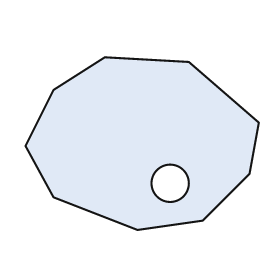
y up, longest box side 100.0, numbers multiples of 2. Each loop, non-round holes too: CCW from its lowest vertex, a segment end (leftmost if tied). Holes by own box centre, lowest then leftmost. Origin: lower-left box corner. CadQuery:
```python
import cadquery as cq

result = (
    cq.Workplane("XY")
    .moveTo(48.0, 0.0)
    .lineTo(76.0, 4.0)
    .lineTo(96.0, 24.0)
    .lineTo(100.0, 46.0)
    .lineTo(70.0, 72.0)
    .lineTo(34.0, 74.0)
    .lineTo(12.0, 60.0)
    .lineTo(0.0, 36.0)
    .lineTo(12.0, 14.0)
    .close()
    .moveTo(62.0, 20.0)
    .circle(8.0)
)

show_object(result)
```